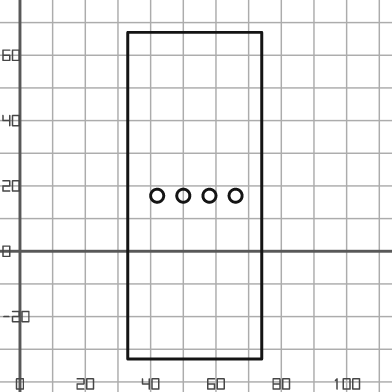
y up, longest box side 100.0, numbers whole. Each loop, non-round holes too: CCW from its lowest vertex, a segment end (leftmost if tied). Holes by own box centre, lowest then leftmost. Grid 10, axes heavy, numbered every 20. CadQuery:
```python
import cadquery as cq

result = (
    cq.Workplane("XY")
    .moveTo(33.0, -33.0)
    .lineTo(74.0, -33.0)
    .lineTo(74.0, 67.0)
    .lineTo(33.0, 67.0)
    .close()
    .moveTo(42.0, 17.0)
    .circle(2.0)
    .moveTo(50.0, 17.0)
    .circle(2.0)
    .moveTo(58.0, 17.0)
    .circle(2.0)
    .moveTo(66.0, 17.0)
    .circle(2.0)
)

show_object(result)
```